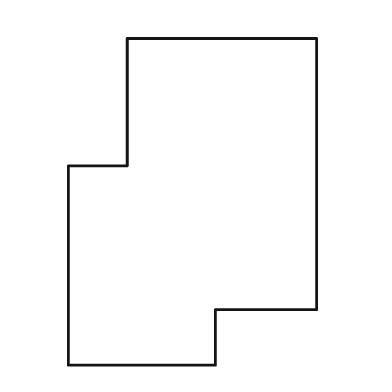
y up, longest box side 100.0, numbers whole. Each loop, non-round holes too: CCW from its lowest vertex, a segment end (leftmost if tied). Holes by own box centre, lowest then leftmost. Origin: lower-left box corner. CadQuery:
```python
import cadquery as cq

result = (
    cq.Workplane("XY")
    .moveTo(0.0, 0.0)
    .lineTo(45.0, 0.0)
    .lineTo(45.0, 17.0)
    .lineTo(76.0, 17.0)
    .lineTo(76.0, 100.0)
    .lineTo(18.0, 100.0)
    .lineTo(18.0, 61.0)
    .lineTo(0.0, 61.0)
    .close()
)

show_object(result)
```